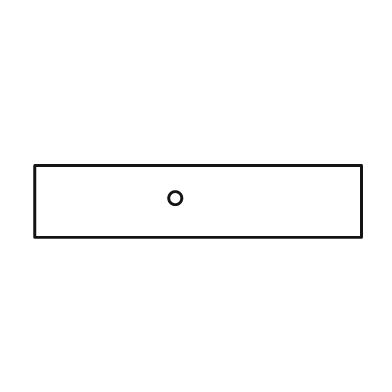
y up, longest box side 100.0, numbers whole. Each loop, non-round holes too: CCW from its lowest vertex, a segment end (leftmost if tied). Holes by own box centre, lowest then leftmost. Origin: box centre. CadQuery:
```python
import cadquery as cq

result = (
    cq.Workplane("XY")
    .moveTo(-50.0, -11.0)
    .lineTo(50.0, -11.0)
    .lineTo(50.0, 11.0)
    .lineTo(-50.0, 11.0)
    .close()
    .moveTo(-7.0, 1.0)
    .circle(2.0)
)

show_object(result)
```